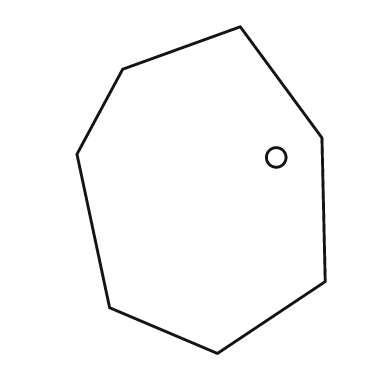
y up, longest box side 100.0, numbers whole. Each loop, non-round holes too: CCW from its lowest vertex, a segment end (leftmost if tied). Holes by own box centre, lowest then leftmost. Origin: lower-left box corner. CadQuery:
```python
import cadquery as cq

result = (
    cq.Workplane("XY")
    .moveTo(43.0, 0.0)
    .lineTo(76.0, 22.0)
    .lineTo(75.0, 66.0)
    .lineTo(50.0, 100.0)
    .lineTo(14.0, 87.0)
    .lineTo(0.0, 61.0)
    .lineTo(10.0, 14.0)
    .close()
    .moveTo(61.0, 60.0)
    .circle(3.0)
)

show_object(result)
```